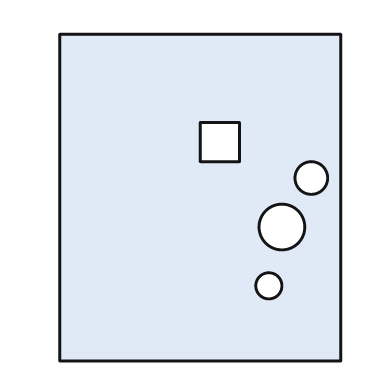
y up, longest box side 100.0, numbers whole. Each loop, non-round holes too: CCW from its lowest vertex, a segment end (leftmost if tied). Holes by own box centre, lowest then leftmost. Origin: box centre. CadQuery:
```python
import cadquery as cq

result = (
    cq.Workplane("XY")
    .moveTo(-43.0, -50.0)
    .lineTo(43.0, -50.0)
    .lineTo(43.0, 50.0)
    .lineTo(-43.0, 50.0)
    .close()
    .moveTo(21.0, -27.0)
    .circle(4.0)
    .moveTo(25.0, -9.0)
    .circle(7.0)
    .moveTo(34.0, 6.0)
    .circle(5.0)
    .moveTo(0.0, 11.0)
    .lineTo(12.0, 11.0)
    .lineTo(12.0, 23.0)
    .lineTo(0.0, 23.0)
    .close()
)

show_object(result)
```